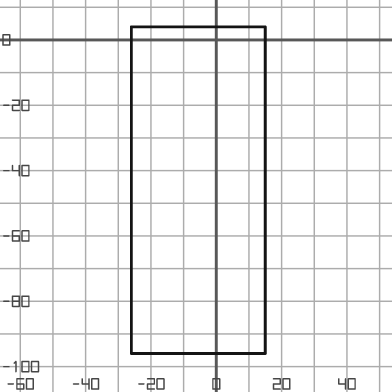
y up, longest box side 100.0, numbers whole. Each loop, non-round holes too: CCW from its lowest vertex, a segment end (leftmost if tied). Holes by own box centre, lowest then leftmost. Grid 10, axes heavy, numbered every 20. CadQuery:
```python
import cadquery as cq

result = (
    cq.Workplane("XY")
    .moveTo(-26.0, -96.0)
    .lineTo(15.0, -96.0)
    .lineTo(15.0, 4.0)
    .lineTo(-26.0, 4.0)
    .close()
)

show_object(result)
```